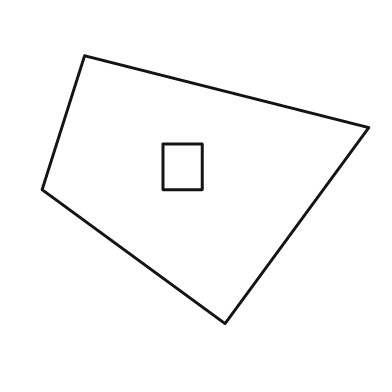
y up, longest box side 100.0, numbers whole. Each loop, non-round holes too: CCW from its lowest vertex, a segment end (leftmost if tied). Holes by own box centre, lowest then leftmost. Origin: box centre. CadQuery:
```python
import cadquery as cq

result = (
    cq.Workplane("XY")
    .moveTo(6.0, -41.0)
    .lineTo(50.0, 19.0)
    .lineTo(-37.0, 41.0)
    .lineTo(-50.0, 0.0)
    .close()
    .moveTo(-13.0, 0.0)
    .lineTo(-1.0, 0.0)
    .lineTo(-1.0, 14.0)
    .lineTo(-13.0, 14.0)
    .close()
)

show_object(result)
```